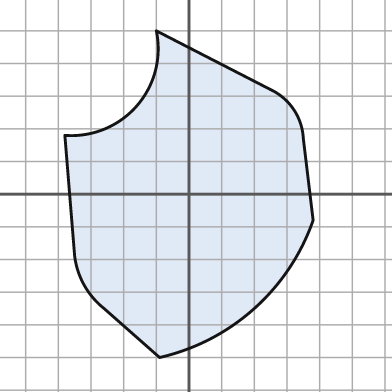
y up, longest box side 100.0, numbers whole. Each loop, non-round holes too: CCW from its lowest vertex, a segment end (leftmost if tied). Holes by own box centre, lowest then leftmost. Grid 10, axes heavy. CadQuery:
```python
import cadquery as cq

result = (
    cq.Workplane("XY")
    .moveTo(-9.0, -50.0)
    .threePointArc((20.0, -35.0), (38.0, -8.0))
    .lineTo(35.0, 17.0)
    .threePointArc((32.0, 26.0), (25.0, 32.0))
    .lineTo(-10.0, 50.0)
    .threePointArc((-16.0, 27.0), (-38.0, 18.0))
    .lineTo(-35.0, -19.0)
    .threePointArc((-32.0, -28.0), (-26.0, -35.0))
    .close()
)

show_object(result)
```